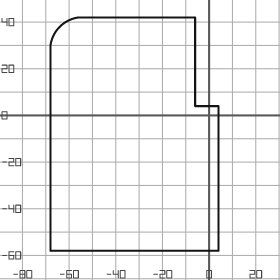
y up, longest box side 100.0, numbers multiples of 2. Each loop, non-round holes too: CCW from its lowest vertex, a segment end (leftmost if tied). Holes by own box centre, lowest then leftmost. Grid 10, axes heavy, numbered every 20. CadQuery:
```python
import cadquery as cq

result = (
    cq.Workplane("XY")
    .moveTo(-68.0, -58.0)
    .lineTo(4.0, -58.0)
    .lineTo(4.0, 4.0)
    .lineTo(-6.0, 4.0)
    .lineTo(-6.0, 42.0)
    .lineTo(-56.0, 42.0)
    .threePointArc((-64.0, 38.0), (-68.0, 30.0))
    .close()
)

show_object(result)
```